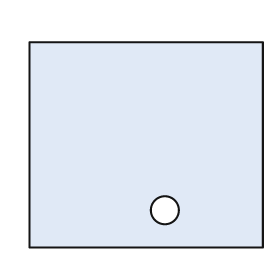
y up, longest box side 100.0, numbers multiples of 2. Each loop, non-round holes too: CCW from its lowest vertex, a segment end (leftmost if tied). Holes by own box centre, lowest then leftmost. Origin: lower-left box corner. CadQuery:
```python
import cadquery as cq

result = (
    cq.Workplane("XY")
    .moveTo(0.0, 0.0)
    .lineTo(100.0, 0.0)
    .lineTo(100.0, 88.0)
    .lineTo(0.0, 88.0)
    .close()
    .moveTo(58.0, 16.0)
    .circle(6.0)
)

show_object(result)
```